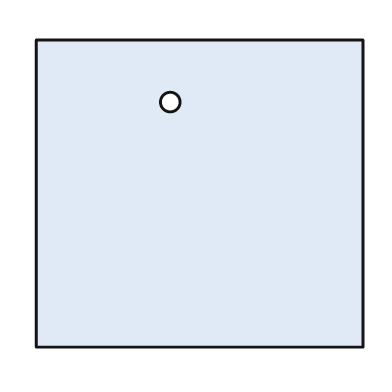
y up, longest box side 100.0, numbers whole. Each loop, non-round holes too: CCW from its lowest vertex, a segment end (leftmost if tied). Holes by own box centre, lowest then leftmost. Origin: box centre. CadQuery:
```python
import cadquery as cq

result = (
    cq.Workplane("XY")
    .moveTo(-50.0, -47.0)
    .lineTo(50.0, -47.0)
    .lineTo(50.0, 47.0)
    .lineTo(-50.0, 47.0)
    .close()
    .moveTo(-9.0, 28.0)
    .circle(3.0)
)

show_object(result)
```